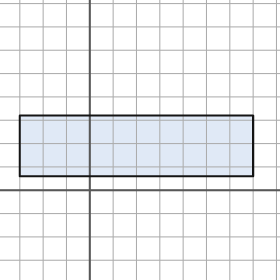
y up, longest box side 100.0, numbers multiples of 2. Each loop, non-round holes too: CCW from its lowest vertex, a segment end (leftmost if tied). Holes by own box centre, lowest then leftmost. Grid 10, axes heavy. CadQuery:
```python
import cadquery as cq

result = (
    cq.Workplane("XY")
    .moveTo(-30.0, 6.0)
    .lineTo(70.0, 6.0)
    .lineTo(70.0, 32.0)
    .lineTo(-30.0, 32.0)
    .close()
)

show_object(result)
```